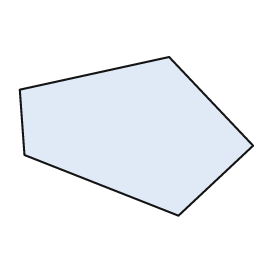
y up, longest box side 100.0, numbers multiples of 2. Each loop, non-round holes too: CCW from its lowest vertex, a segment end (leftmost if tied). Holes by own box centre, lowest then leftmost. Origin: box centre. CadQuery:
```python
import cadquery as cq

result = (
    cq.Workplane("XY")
    .moveTo(18.0, -34.0)
    .lineTo(50.0, -4.0)
    .lineTo(14.0, 34.0)
    .lineTo(-50.0, 20.0)
    .lineTo(-48.0, -8.0)
    .close()
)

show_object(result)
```